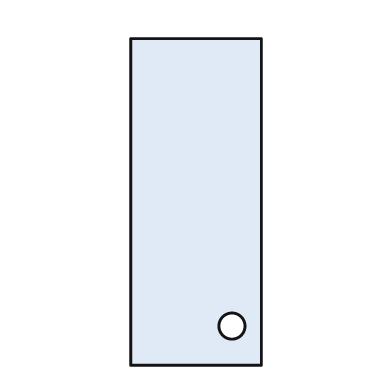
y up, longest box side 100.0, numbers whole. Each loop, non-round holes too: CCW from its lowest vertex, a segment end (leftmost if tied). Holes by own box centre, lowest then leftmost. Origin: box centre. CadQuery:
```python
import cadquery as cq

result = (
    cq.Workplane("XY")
    .moveTo(-20.0, -50.0)
    .lineTo(20.0, -50.0)
    .lineTo(20.0, 50.0)
    .lineTo(-20.0, 50.0)
    .close()
    .moveTo(11.0, -38.0)
    .circle(4.0)
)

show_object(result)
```